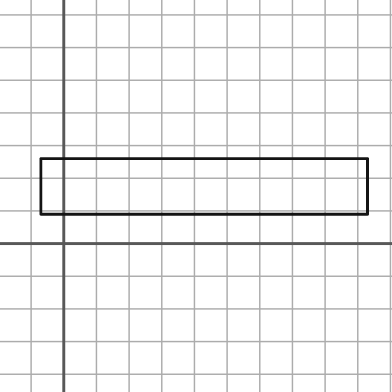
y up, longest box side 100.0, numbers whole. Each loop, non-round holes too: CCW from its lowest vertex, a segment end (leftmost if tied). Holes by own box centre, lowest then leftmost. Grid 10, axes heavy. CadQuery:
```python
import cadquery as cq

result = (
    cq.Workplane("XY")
    .moveTo(-7.0, 9.0)
    .lineTo(93.0, 9.0)
    .lineTo(93.0, 26.0)
    .lineTo(-7.0, 26.0)
    .close()
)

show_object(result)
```